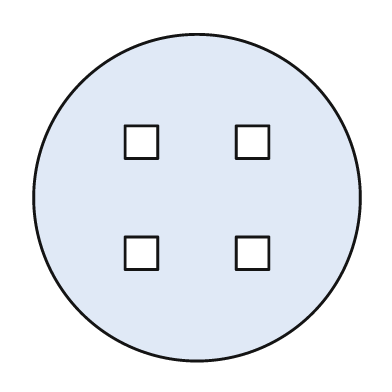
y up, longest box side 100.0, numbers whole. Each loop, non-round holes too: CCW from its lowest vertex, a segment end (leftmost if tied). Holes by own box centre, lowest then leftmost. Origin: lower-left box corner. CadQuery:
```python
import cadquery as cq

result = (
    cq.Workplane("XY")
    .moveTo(50.0, 50.0)
    .circle(50.0)
    .moveTo(28.0, 28.0)
    .lineTo(38.0, 28.0)
    .lineTo(38.0, 38.0)
    .lineTo(28.0, 38.0)
    .close()
    .moveTo(62.0, 28.0)
    .lineTo(72.0, 28.0)
    .lineTo(72.0, 38.0)
    .lineTo(62.0, 38.0)
    .close()
    .moveTo(28.0, 62.0)
    .lineTo(38.0, 62.0)
    .lineTo(38.0, 72.0)
    .lineTo(28.0, 72.0)
    .close()
    .moveTo(62.0, 62.0)
    .lineTo(72.0, 62.0)
    .lineTo(72.0, 72.0)
    .lineTo(62.0, 72.0)
    .close()
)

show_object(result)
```